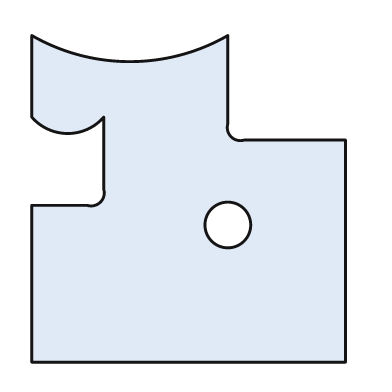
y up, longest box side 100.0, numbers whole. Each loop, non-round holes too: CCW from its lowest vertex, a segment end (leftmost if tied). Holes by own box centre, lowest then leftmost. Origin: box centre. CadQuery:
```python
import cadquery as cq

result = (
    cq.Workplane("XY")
    .moveTo(-48.0, -50.0)
    .lineTo(48.0, -50.0)
    .lineTo(48.0, 18.0)
    .lineTo(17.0, 18.0)
    .threePointArc((13.0, 19.0), (12.0, 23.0))
    .lineTo(12.0, 50.0)
    .threePointArc((-18.0, 42.0), (-48.0, 50.0))
    .lineTo(-48.0, 25.0)
    .threePointArc((-37.0, 20.0), (-26.0, 25.0))
    .lineTo(-26.0, 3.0)
    .threePointArc((-27.0, -1.0), (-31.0, -2.0))
    .lineTo(-48.0, -2.0)
    .close()
    .moveTo(12.0, -8.0)
    .circle(7.0)
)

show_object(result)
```